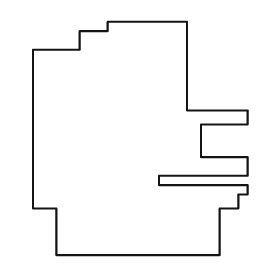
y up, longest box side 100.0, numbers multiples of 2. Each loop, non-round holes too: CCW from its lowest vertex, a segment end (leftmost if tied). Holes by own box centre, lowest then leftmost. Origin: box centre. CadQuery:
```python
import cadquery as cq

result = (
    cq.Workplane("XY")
    .moveTo(-36.0, -50.0)
    .lineTo(34.0, -50.0)
    .lineTo(34.0, -30.0)
    .lineTo(42.0, -30.0)
    .lineTo(42.0, -24.0)
    .lineTo(46.0, -24.0)
    .lineTo(46.0, -20.0)
    .lineTo(8.0, -20.0)
    .lineTo(8.0, -16.0)
    .lineTo(46.0, -16.0)
    .lineTo(46.0, -8.0)
    .lineTo(26.0, -8.0)
    .lineTo(26.0, 6.0)
    .lineTo(46.0, 6.0)
    .lineTo(46.0, 12.0)
    .lineTo(20.0, 12.0)
    .lineTo(20.0, 50.0)
    .lineTo(-14.0, 50.0)
    .lineTo(-14.0, 46.0)
    .lineTo(-26.0, 46.0)
    .lineTo(-26.0, 38.0)
    .lineTo(-46.0, 38.0)
    .lineTo(-46.0, -30.0)
    .lineTo(-36.0, -30.0)
    .close()
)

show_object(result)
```